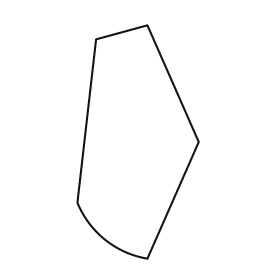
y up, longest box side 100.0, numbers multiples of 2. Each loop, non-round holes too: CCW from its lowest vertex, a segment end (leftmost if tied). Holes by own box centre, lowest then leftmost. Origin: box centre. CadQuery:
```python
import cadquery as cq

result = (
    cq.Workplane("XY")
    .moveTo(4.0, -50.0)
    .lineTo(26.0, 0.0)
    .lineTo(4.0, 50.0)
    .lineTo(-18.0, 44.0)
    .lineTo(-26.0, -26.0)
    .threePointArc((-14.0, -42.0), (4.0, -50.0))
    .close()
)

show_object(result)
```